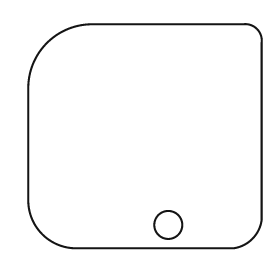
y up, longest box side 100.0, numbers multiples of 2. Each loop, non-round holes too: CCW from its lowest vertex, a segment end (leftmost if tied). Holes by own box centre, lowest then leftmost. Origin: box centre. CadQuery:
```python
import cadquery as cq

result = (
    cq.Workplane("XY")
    .moveTo(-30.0, -48.0)
    .lineTo(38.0, -48.0)
    .threePointArc((46.0, -44.0), (50.0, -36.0))
    .lineTo(50.0, 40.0)
    .threePointArc((48.0, 46.0), (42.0, 48.0))
    .lineTo(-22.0, 48.0)
    .threePointArc((-42.0, 40.0), (-50.0, 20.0))
    .lineTo(-50.0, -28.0)
    .threePointArc((-44.0, -42.0), (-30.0, -48.0))
    .close()
    .moveTo(10.0, -38.0)
    .circle(6.0)
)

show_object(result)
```